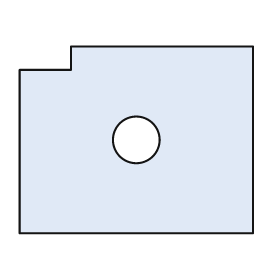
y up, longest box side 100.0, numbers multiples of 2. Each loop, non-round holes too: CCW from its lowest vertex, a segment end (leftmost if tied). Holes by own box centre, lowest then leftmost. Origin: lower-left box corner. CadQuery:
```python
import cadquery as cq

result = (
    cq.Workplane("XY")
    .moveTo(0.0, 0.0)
    .lineTo(100.0, 0.0)
    .lineTo(100.0, 80.0)
    .lineTo(22.0, 80.0)
    .lineTo(22.0, 70.0)
    .lineTo(0.0, 70.0)
    .close()
    .moveTo(50.0, 40.0)
    .circle(10.0)
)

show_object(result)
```